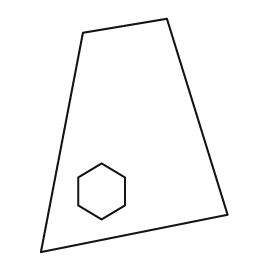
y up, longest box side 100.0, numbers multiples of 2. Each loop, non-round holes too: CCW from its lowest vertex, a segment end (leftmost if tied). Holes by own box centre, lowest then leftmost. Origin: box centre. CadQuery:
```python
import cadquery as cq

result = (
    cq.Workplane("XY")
    .moveTo(-40.0, -50.0)
    .lineTo(40.0, -34.0)
    .lineTo(14.0, 50.0)
    .lineTo(-22.0, 44.0)
    .close()
    .moveTo(-14.0, -36.0)
    .lineTo(-4.0, -30.0)
    .lineTo(-4.0, -18.0)
    .lineTo(-14.0, -12.0)
    .lineTo(-24.0, -18.0)
    .lineTo(-24.0, -30.0)
    .close()
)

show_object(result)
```